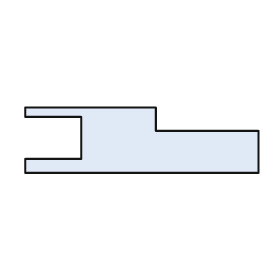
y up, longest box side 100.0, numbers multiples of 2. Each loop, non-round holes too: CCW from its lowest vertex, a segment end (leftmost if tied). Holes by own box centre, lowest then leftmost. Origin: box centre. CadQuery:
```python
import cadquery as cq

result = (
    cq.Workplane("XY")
    .moveTo(-50.0, -14.0)
    .lineTo(50.0, -14.0)
    .lineTo(50.0, 4.0)
    .lineTo(6.0, 4.0)
    .lineTo(6.0, 14.0)
    .lineTo(-50.0, 14.0)
    .lineTo(-50.0, 10.0)
    .lineTo(-26.0, 10.0)
    .lineTo(-26.0, -8.0)
    .lineTo(-50.0, -8.0)
    .close()
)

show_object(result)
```